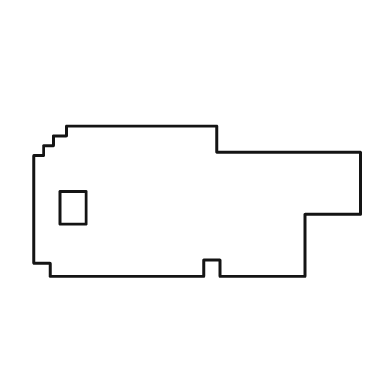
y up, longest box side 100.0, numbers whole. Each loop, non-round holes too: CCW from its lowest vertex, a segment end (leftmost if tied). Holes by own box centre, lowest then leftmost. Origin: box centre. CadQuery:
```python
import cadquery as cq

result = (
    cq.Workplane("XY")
    .moveTo(-45.0, -23.0)
    .lineTo(2.0, -23.0)
    .lineTo(2.0, -18.0)
    .lineTo(7.0, -18.0)
    .lineTo(7.0, -23.0)
    .lineTo(33.0, -23.0)
    .lineTo(33.0, -4.0)
    .lineTo(50.0, -4.0)
    .lineTo(50.0, 15.0)
    .lineTo(6.0, 15.0)
    .lineTo(6.0, 23.0)
    .lineTo(-40.0, 23.0)
    .lineTo(-40.0, 20.0)
    .lineTo(-44.0, 20.0)
    .lineTo(-44.0, 17.0)
    .lineTo(-47.0, 17.0)
    .lineTo(-47.0, 14.0)
    .lineTo(-50.0, 14.0)
    .lineTo(-50.0, -19.0)
    .lineTo(-45.0, -19.0)
    .close()
    .moveTo(-42.0, -7.0)
    .lineTo(-34.0, -7.0)
    .lineTo(-34.0, 3.0)
    .lineTo(-42.0, 3.0)
    .close()
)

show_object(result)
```